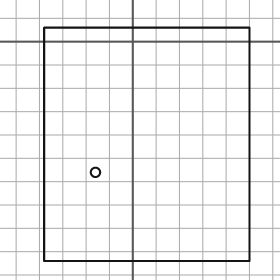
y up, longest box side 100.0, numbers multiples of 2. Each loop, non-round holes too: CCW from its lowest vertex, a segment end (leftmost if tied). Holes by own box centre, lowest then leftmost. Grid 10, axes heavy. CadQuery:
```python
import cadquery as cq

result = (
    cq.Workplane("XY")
    .moveTo(-38.0, -94.0)
    .lineTo(50.0, -94.0)
    .lineTo(50.0, 6.0)
    .lineTo(-38.0, 6.0)
    .close()
    .moveTo(-16.0, -56.0)
    .circle(2.0)
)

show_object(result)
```